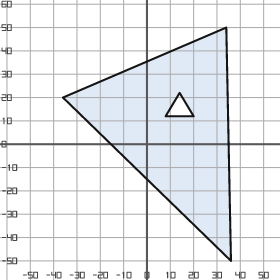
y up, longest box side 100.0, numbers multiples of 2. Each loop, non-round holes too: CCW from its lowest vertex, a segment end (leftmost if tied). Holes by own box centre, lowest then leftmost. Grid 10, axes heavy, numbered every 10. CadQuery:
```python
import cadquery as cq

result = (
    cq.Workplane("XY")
    .moveTo(36.0, -50.0)
    .lineTo(34.0, 50.0)
    .lineTo(-36.0, 20.0)
    .close()
    .moveTo(8.0, 12.0)
    .lineTo(20.0, 12.0)
    .lineTo(14.0, 22.0)
    .close()
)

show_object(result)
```